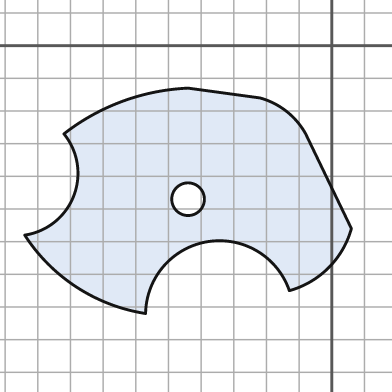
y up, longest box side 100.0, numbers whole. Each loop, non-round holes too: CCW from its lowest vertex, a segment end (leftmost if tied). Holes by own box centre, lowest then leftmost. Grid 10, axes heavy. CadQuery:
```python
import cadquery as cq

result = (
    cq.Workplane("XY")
    .moveTo(-57.0, -82.0)
    .threePointArc((-38.0, -60.0), (-13.0, -75.0))
    .threePointArc((-1.0, -68.0), (6.0, -56.0))
    .lineTo(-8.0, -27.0)
    .threePointArc((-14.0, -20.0), (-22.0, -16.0))
    .lineTo(-44.0, -13.0)
    .threePointArc((-64.0, -17.0), (-82.0, -27.0))
    .threePointArc((-79.0, -46.0), (-94.0, -58.0))
    .threePointArc((-78.0, -74.0), (-57.0, -82.0))
    .close()
    .moveTo(-44.0, -47.0)
    .circle(5.0)
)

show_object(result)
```